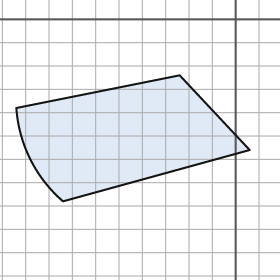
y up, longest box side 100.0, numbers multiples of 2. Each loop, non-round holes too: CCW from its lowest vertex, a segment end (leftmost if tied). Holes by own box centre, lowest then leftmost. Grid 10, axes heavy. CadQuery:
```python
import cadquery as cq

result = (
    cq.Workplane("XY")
    .moveTo(-74.0, -78.0)
    .lineTo(6.0, -56.0)
    .lineTo(-24.0, -24.0)
    .lineTo(-94.0, -38.0)
    .threePointArc((-88.0, -60.0), (-74.0, -78.0))
    .close()
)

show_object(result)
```